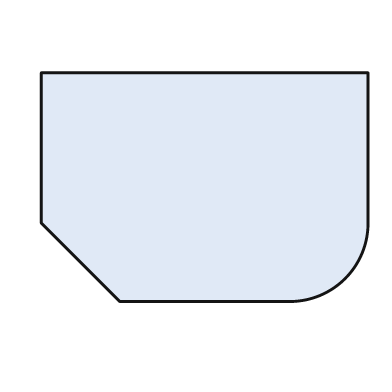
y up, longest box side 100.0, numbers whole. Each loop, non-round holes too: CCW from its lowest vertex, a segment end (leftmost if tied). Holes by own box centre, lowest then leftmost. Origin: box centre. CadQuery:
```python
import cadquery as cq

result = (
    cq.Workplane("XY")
    .moveTo(-26.0, -35.0)
    .lineTo(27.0, -35.0)
    .threePointArc((43.0, -28.0), (50.0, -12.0))
    .lineTo(50.0, 35.0)
    .lineTo(-50.0, 35.0)
    .lineTo(-50.0, -11.0)
    .close()
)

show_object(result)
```